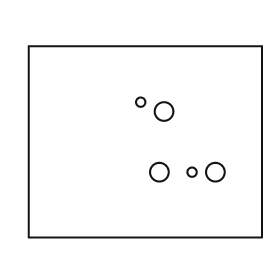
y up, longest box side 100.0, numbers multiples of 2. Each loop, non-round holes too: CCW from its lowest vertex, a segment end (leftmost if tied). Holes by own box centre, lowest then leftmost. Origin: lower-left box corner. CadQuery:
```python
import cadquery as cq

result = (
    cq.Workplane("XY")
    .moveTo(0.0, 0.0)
    .lineTo(100.0, 0.0)
    .lineTo(100.0, 82.0)
    .lineTo(0.0, 82.0)
    .close()
    .moveTo(56.0, 28.0)
    .circle(4.0)
    .moveTo(70.0, 28.0)
    .circle(2.0)
    .moveTo(80.0, 28.0)
    .circle(4.0)
    .moveTo(58.0, 54.0)
    .circle(4.0)
    .moveTo(48.0, 58.0)
    .circle(2.0)
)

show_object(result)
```